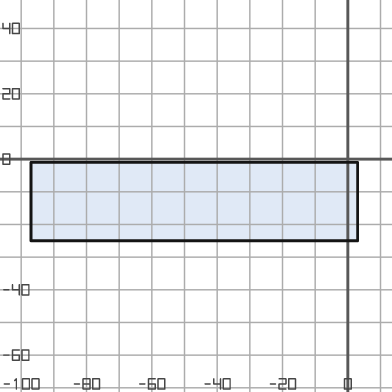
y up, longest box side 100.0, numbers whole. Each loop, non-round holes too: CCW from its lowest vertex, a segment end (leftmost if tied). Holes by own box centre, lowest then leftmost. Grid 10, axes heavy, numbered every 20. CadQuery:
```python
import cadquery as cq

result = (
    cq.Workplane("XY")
    .moveTo(-97.0, -25.0)
    .lineTo(3.0, -25.0)
    .lineTo(3.0, -1.0)
    .lineTo(-97.0, -1.0)
    .close()
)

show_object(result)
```